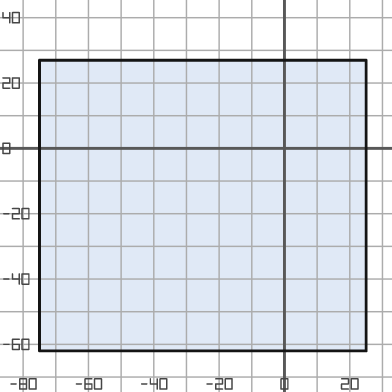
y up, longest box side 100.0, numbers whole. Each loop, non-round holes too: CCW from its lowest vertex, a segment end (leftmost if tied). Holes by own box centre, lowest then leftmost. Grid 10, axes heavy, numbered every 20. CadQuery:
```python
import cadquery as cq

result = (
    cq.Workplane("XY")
    .moveTo(-75.0, -62.0)
    .lineTo(25.0, -62.0)
    .lineTo(25.0, 27.0)
    .lineTo(-75.0, 27.0)
    .close()
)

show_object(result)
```